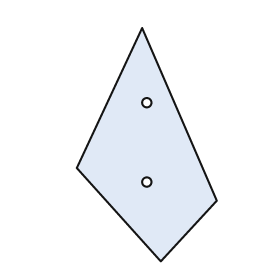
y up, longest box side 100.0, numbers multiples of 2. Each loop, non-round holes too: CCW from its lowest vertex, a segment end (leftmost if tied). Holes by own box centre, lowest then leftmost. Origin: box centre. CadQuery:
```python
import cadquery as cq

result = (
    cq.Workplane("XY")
    .moveTo(6.0, -50.0)
    .lineTo(30.0, -24.0)
    .lineTo(-2.0, 50.0)
    .lineTo(-30.0, -10.0)
    .close()
    .moveTo(0.0, -16.0)
    .circle(2.0)
    .moveTo(0.0, 18.0)
    .circle(2.0)
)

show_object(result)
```